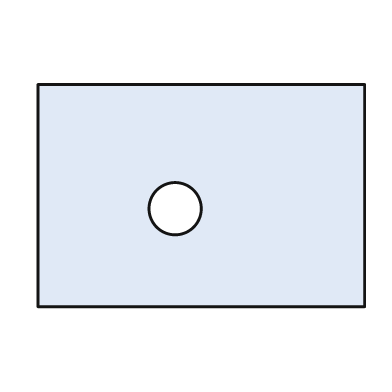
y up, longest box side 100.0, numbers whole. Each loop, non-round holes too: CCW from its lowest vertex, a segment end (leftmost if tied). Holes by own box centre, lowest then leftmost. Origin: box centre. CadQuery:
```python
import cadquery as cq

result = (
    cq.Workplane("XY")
    .moveTo(-50.0, -34.0)
    .lineTo(50.0, -34.0)
    .lineTo(50.0, 34.0)
    .lineTo(-50.0, 34.0)
    .close()
    .moveTo(-8.0, -4.0)
    .circle(8.0)
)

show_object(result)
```